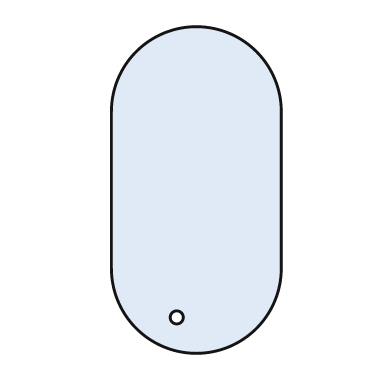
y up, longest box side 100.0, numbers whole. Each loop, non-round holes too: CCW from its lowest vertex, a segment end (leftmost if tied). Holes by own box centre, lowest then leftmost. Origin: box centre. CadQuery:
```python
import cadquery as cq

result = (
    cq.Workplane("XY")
    .moveTo(-26.0, -24.0)
    .threePointArc((0.0, -50.0), (26.0, -24.0))
    .lineTo(26.0, 24.0)
    .threePointArc((0.0, 50.0), (-26.0, 24.0))
    .close()
    .moveTo(-6.0, -39.0)
    .circle(2.0)
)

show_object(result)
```